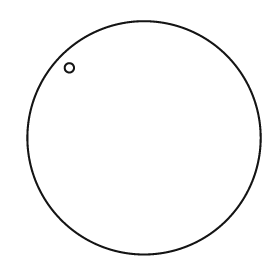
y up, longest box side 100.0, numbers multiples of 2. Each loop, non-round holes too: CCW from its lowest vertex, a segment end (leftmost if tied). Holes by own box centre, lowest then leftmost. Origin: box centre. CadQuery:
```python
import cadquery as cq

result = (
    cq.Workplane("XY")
    .moveTo(0.0, 0.0)
    .circle(50.0)
    .moveTo(-32.0, 30.0)
    .circle(2.0)
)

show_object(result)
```